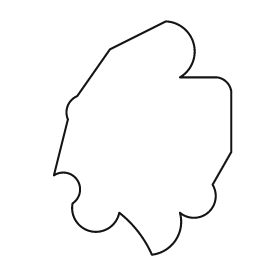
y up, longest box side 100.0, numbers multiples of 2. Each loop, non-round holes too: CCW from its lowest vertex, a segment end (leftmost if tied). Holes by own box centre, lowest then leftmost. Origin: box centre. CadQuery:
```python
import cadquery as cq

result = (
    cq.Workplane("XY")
    .moveTo(4.0, -50.0)
    .threePointArc((14.0, -44.0), (16.0, -32.0))
    .threePointArc((28.0, -32.0), (30.0, -20.0))
    .lineTo(38.0, -6.0)
    .lineTo(38.0, 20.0)
    .threePointArc((36.0, 24.0), (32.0, 26.0))
    .lineTo(16.0, 26.0)
    .threePointArc((22.0, 40.0), (10.0, 50.0))
    .lineTo(-14.0, 38.0)
    .lineTo(-28.0, 18.0)
    .threePointArc((-32.0, 14.0), (-32.0, 8.0))
    .lineTo(-38.0, -16.0)
    .threePointArc((-28.0, -18.0), (-30.0, -28.0))
    .threePointArc((-22.0, -40.0), (-10.0, -32.0))
    .threePointArc((-2.0, -40.0), (4.0, -50.0))
    .close()
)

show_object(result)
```